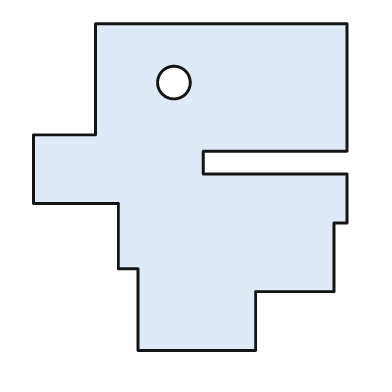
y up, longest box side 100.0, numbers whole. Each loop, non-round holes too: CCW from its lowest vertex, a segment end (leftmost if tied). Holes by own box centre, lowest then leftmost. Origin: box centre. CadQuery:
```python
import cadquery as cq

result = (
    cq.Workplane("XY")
    .moveTo(-16.0, -50.0)
    .lineTo(20.0, -50.0)
    .lineTo(20.0, -32.0)
    .lineTo(44.0, -32.0)
    .lineTo(44.0, -11.0)
    .lineTo(48.0, -11.0)
    .lineTo(48.0, 4.0)
    .lineTo(4.0, 4.0)
    .lineTo(4.0, 11.0)
    .lineTo(48.0, 11.0)
    .lineTo(48.0, 50.0)
    .lineTo(-29.0, 50.0)
    .lineTo(-29.0, 16.0)
    .lineTo(-48.0, 16.0)
    .lineTo(-48.0, -5.0)
    .lineTo(-22.0, -5.0)
    .lineTo(-22.0, -25.0)
    .lineTo(-16.0, -25.0)
    .close()
    .moveTo(-5.0, 32.0)
    .circle(5.0)
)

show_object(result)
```